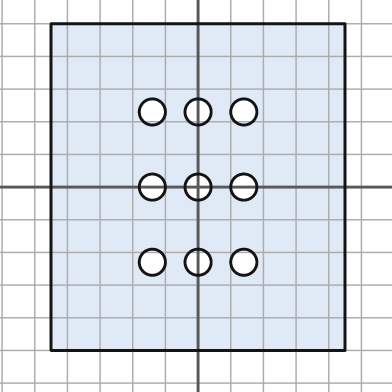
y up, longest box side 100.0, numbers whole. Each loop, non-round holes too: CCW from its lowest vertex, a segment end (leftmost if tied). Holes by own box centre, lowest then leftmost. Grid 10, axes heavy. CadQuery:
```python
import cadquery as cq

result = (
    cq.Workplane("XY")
    .moveTo(-45.0, -50.0)
    .lineTo(45.0, -50.0)
    .lineTo(45.0, 50.0)
    .lineTo(-45.0, 50.0)
    .close()
    .moveTo(-14.0, -23.0)
    .circle(4.0)
    .moveTo(0.0, -23.0)
    .circle(4.0)
    .moveTo(14.0, -23.0)
    .circle(4.0)
    .moveTo(-14.0, 0.0)
    .circle(4.0)
    .moveTo(0.0, 0.0)
    .circle(4.0)
    .moveTo(14.0, 0.0)
    .circle(4.0)
    .moveTo(-14.0, 23.0)
    .circle(4.0)
    .moveTo(0.0, 23.0)
    .circle(4.0)
    .moveTo(14.0, 23.0)
    .circle(4.0)
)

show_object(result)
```